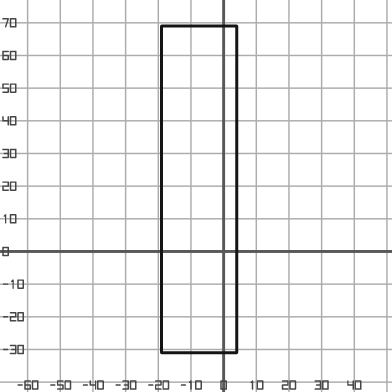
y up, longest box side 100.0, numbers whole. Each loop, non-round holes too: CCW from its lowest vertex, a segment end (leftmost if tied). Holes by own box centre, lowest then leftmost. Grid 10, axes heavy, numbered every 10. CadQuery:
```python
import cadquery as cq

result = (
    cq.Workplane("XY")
    .moveTo(-19.0, -31.0)
    .lineTo(4.0, -31.0)
    .lineTo(4.0, 69.0)
    .lineTo(-19.0, 69.0)
    .close()
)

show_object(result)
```